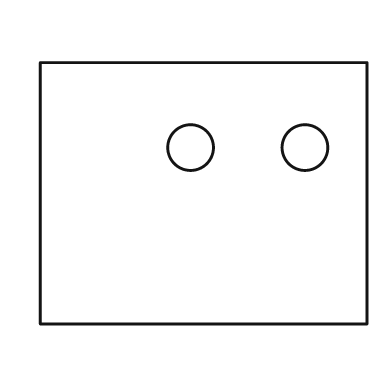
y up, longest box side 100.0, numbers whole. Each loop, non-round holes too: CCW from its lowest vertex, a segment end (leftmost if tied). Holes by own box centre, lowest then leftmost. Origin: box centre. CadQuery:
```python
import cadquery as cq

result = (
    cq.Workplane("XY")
    .moveTo(-50.0, -40.0)
    .lineTo(50.0, -40.0)
    .lineTo(50.0, 40.0)
    .lineTo(-50.0, 40.0)
    .close()
    .moveTo(-4.0, 14.0)
    .circle(7.0)
    .moveTo(31.0, 14.0)
    .circle(7.0)
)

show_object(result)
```